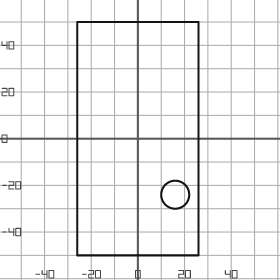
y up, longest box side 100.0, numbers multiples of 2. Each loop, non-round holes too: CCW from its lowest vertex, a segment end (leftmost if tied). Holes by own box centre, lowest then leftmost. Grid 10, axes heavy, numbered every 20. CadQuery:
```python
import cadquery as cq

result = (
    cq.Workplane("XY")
    .moveTo(-26.0, -50.0)
    .lineTo(26.0, -50.0)
    .lineTo(26.0, 50.0)
    .lineTo(-26.0, 50.0)
    .close()
    .moveTo(16.0, -24.0)
    .circle(6.0)
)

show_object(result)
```